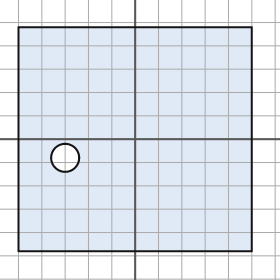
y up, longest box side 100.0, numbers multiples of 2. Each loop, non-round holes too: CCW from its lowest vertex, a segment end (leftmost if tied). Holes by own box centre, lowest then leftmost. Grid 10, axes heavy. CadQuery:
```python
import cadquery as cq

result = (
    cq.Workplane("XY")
    .moveTo(-50.0, -48.0)
    .lineTo(50.0, -48.0)
    .lineTo(50.0, 48.0)
    .lineTo(-50.0, 48.0)
    .close()
    .moveTo(-30.0, -8.0)
    .circle(6.0)
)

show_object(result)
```